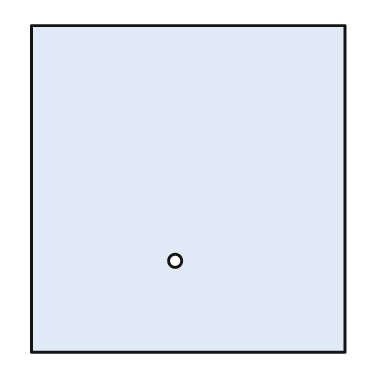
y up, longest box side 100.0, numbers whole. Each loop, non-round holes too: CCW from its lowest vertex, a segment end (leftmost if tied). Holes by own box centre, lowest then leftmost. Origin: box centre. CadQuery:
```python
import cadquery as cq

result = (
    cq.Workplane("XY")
    .moveTo(-48.0, -50.0)
    .lineTo(48.0, -50.0)
    .lineTo(48.0, 50.0)
    .lineTo(-48.0, 50.0)
    .close()
    .moveTo(-4.0, -22.0)
    .circle(2.0)
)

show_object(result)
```